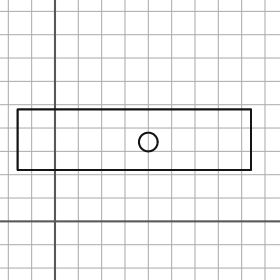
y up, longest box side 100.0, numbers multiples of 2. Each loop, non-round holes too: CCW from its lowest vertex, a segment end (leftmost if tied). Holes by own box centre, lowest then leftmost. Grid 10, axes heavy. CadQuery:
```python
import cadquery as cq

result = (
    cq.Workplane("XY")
    .moveTo(-16.0, 22.0)
    .lineTo(84.0, 22.0)
    .lineTo(84.0, 48.0)
    .lineTo(-16.0, 48.0)
    .close()
    .moveTo(40.0, 34.0)
    .circle(4.0)
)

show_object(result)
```